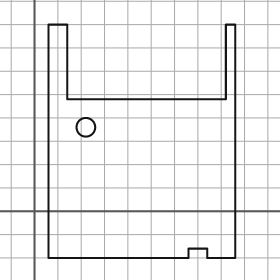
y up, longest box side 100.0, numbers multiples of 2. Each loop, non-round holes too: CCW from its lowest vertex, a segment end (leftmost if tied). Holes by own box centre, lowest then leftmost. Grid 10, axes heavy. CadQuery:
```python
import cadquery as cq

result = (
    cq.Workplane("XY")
    .moveTo(6.0, -20.0)
    .lineTo(66.0, -20.0)
    .lineTo(66.0, -16.0)
    .lineTo(74.0, -16.0)
    .lineTo(74.0, -20.0)
    .lineTo(86.0, -20.0)
    .lineTo(86.0, 80.0)
    .lineTo(82.0, 80.0)
    .lineTo(82.0, 48.0)
    .lineTo(14.0, 48.0)
    .lineTo(14.0, 80.0)
    .lineTo(6.0, 80.0)
    .close()
    .moveTo(22.0, 36.0)
    .circle(4.0)
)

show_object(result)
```